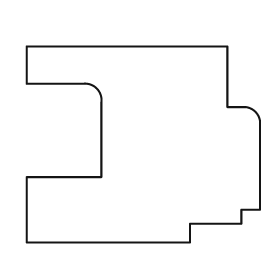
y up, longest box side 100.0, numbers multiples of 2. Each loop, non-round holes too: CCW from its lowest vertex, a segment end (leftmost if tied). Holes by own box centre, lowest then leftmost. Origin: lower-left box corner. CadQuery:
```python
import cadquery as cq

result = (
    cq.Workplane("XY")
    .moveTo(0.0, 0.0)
    .lineTo(70.0, 0.0)
    .lineTo(70.0, 8.0)
    .lineTo(92.0, 8.0)
    .lineTo(92.0, 14.0)
    .lineTo(100.0, 14.0)
    .lineTo(100.0, 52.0)
    .threePointArc((98.0, 56.0), (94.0, 58.0))
    .lineTo(86.0, 58.0)
    .lineTo(86.0, 84.0)
    .lineTo(0.0, 84.0)
    .lineTo(0.0, 68.0)
    .lineTo(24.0, 68.0)
    .threePointArc((30.0, 66.0), (32.0, 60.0))
    .lineTo(32.0, 28.0)
    .lineTo(0.0, 28.0)
    .close()
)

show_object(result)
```